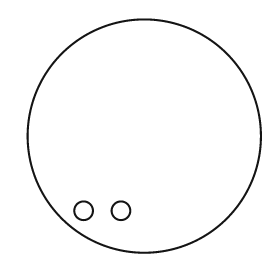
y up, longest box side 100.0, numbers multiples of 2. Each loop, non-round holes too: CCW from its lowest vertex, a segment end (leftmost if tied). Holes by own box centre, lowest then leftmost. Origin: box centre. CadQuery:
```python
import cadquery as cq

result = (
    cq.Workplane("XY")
    .moveTo(0.0, 0.0)
    .circle(50.0)
    .moveTo(-26.0, -32.0)
    .circle(4.0)
    .moveTo(-10.0, -32.0)
    .circle(4.0)
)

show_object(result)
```